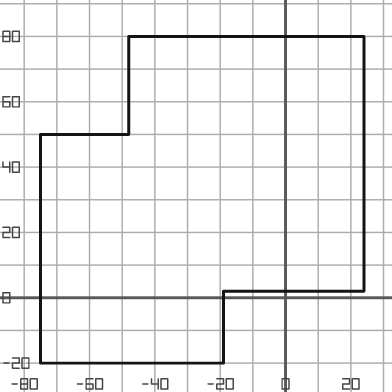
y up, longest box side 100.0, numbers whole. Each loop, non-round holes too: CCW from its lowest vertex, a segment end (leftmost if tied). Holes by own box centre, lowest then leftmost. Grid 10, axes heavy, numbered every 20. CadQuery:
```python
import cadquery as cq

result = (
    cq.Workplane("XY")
    .moveTo(-75.0, -20.0)
    .lineTo(-19.0, -20.0)
    .lineTo(-19.0, 2.0)
    .lineTo(24.0, 2.0)
    .lineTo(24.0, 80.0)
    .lineTo(-48.0, 80.0)
    .lineTo(-48.0, 50.0)
    .lineTo(-75.0, 50.0)
    .close()
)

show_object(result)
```